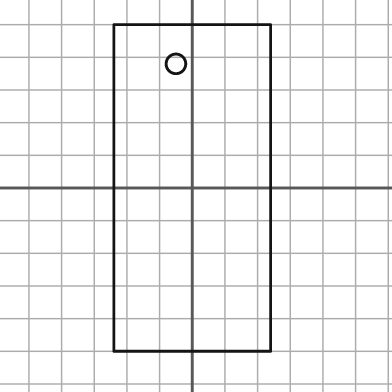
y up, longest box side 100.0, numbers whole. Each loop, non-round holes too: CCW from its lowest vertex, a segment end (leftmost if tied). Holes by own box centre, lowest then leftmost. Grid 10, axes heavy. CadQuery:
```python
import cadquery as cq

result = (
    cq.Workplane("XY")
    .moveTo(-24.0, -50.0)
    .lineTo(24.0, -50.0)
    .lineTo(24.0, 50.0)
    .lineTo(-24.0, 50.0)
    .close()
    .moveTo(-5.0, 38.0)
    .circle(3.0)
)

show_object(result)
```